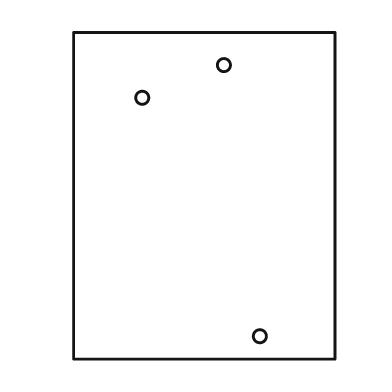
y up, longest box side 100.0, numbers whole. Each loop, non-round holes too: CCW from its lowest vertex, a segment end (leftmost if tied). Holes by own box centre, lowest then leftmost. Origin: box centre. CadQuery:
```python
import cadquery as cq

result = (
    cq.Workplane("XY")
    .moveTo(-40.0, -50.0)
    .lineTo(40.0, -50.0)
    .lineTo(40.0, 50.0)
    .lineTo(-40.0, 50.0)
    .close()
    .moveTo(17.0, -43.0)
    .circle(2.0)
    .moveTo(-19.0, 30.0)
    .circle(2.0)
    .moveTo(6.0, 40.0)
    .circle(2.0)
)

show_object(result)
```